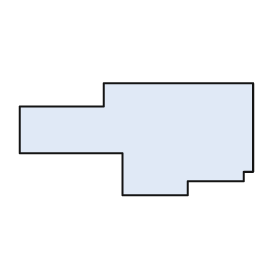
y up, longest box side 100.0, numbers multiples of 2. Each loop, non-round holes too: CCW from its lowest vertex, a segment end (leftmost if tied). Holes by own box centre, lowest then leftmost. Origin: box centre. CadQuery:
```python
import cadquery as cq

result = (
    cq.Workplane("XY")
    .moveTo(-6.0, -24.0)
    .lineTo(22.0, -24.0)
    .lineTo(22.0, -18.0)
    .lineTo(46.0, -18.0)
    .lineTo(46.0, -14.0)
    .lineTo(50.0, -14.0)
    .lineTo(50.0, 24.0)
    .lineTo(-14.0, 24.0)
    .lineTo(-14.0, 14.0)
    .lineTo(-50.0, 14.0)
    .lineTo(-50.0, -6.0)
    .lineTo(-6.0, -6.0)
    .close()
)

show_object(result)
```